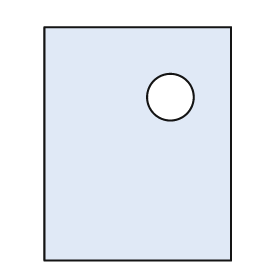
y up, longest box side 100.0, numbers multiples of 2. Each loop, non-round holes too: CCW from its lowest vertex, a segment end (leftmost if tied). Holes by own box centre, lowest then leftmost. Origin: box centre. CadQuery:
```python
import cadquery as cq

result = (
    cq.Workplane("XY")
    .moveTo(-40.0, -50.0)
    .lineTo(40.0, -50.0)
    .lineTo(40.0, 50.0)
    .lineTo(-40.0, 50.0)
    .close()
    .moveTo(14.0, 20.0)
    .circle(10.0)
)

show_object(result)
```